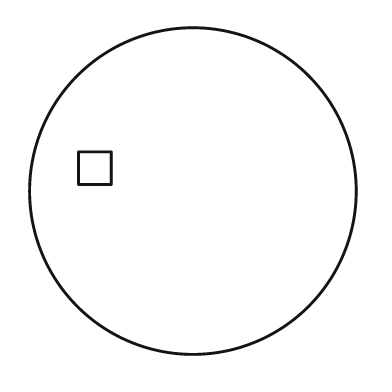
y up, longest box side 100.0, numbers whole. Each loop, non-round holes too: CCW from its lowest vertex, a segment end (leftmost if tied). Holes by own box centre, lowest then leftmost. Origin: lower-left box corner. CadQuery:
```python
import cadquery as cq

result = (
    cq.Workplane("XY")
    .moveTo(50.0, 50.0)
    .circle(50.0)
    .moveTo(15.0, 52.0)
    .lineTo(25.0, 52.0)
    .lineTo(25.0, 62.0)
    .lineTo(15.0, 62.0)
    .close()
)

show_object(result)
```